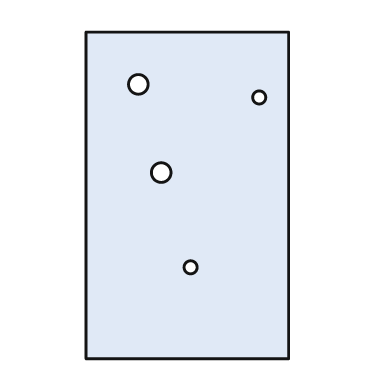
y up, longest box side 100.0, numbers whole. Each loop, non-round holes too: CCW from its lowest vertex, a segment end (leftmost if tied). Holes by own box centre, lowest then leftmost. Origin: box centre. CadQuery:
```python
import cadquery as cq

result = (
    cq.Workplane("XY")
    .moveTo(-31.0, -50.0)
    .lineTo(31.0, -50.0)
    .lineTo(31.0, 50.0)
    .lineTo(-31.0, 50.0)
    .close()
    .moveTo(1.0, -22.0)
    .circle(2.0)
    .moveTo(-8.0, 7.0)
    .circle(3.0)
    .moveTo(22.0, 30.0)
    .circle(2.0)
    .moveTo(-15.0, 34.0)
    .circle(3.0)
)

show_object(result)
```